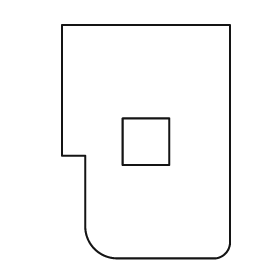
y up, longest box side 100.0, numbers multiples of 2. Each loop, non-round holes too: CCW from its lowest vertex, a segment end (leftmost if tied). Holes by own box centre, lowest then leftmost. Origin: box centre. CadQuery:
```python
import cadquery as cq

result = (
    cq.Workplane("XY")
    .moveTo(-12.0, -50.0)
    .lineTo(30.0, -50.0)
    .threePointArc((34.0, -48.0), (36.0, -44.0))
    .lineTo(36.0, 50.0)
    .lineTo(-36.0, 50.0)
    .lineTo(-36.0, -6.0)
    .lineTo(-26.0, -6.0)
    .lineTo(-26.0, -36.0)
    .threePointArc((-22.0, -46.0), (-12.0, -50.0))
    .close()
    .moveTo(-10.0, -10.0)
    .lineTo(10.0, -10.0)
    .lineTo(10.0, 10.0)
    .lineTo(-10.0, 10.0)
    .close()
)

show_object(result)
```